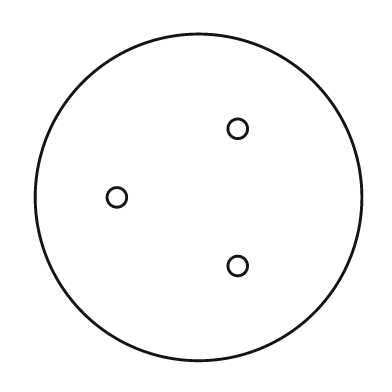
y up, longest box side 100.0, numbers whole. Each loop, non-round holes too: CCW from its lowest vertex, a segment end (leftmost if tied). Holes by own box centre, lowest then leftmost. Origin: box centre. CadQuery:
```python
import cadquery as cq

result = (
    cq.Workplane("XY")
    .moveTo(0.0, 0.0)
    .circle(50.0)
    .moveTo(12.0, -21.0)
    .circle(3.0)
    .moveTo(-25.0, 0.0)
    .circle(3.0)
    .moveTo(12.0, 21.0)
    .circle(3.0)
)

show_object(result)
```